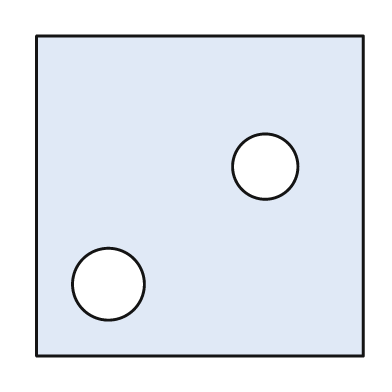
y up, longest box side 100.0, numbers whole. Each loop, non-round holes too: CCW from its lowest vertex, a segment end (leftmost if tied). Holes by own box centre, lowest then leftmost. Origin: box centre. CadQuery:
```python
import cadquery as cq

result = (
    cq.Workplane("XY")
    .moveTo(-50.0, -49.0)
    .lineTo(50.0, -49.0)
    .lineTo(50.0, 49.0)
    .lineTo(-50.0, 49.0)
    .close()
    .moveTo(-28.0, -27.0)
    .circle(11.0)
    .moveTo(20.0, 9.0)
    .circle(10.0)
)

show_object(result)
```